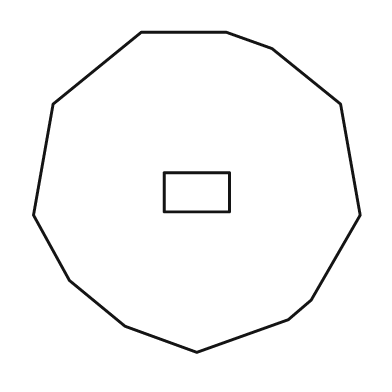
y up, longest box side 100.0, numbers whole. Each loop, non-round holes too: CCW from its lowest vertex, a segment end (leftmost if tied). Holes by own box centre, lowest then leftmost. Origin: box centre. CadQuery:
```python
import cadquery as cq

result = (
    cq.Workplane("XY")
    .moveTo(0.0, -49.0)
    .lineTo(28.0, -39.0)
    .lineTo(35.0, -33.0)
    .lineTo(50.0, -7.0)
    .lineTo(44.0, 27.0)
    .lineTo(23.0, 44.0)
    .lineTo(9.0, 49.0)
    .lineTo(-17.0, 49.0)
    .lineTo(-44.0, 27.0)
    .lineTo(-50.0, -7.0)
    .lineTo(-39.0, -27.0)
    .lineTo(-22.0, -41.0)
    .close()
    .moveTo(-10.0, -6.0)
    .lineTo(10.0, -6.0)
    .lineTo(10.0, 6.0)
    .lineTo(-10.0, 6.0)
    .close()
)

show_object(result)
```